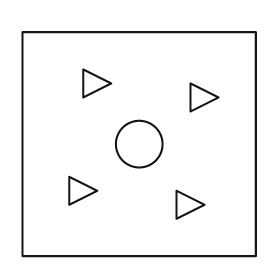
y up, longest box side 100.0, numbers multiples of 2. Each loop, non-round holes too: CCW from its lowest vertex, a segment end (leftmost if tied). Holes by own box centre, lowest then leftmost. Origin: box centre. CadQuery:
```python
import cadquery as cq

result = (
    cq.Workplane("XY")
    .moveTo(-50.0, -48.0)
    .lineTo(50.0, -48.0)
    .lineTo(50.0, 48.0)
    .lineTo(-50.0, 48.0)
    .close()
    .moveTo(16.0, -32.0)
    .lineTo(28.0, -26.0)
    .lineTo(16.0, -20.0)
    .close()
    .moveTo(-30.0, -26.0)
    .lineTo(-18.0, -20.0)
    .lineTo(-30.0, -14.0)
    .close()
    .moveTo(0.0, 0.0)
    .circle(10.0)
    .moveTo(22.0, 14.0)
    .lineTo(34.0, 20.0)
    .lineTo(22.0, 26.0)
    .close()
    .moveTo(-24.0, 20.0)
    .lineTo(-12.0, 26.0)
    .lineTo(-24.0, 32.0)
    .close()
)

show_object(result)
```